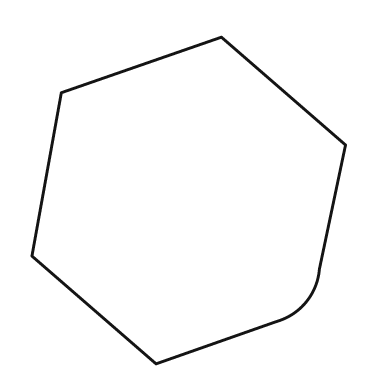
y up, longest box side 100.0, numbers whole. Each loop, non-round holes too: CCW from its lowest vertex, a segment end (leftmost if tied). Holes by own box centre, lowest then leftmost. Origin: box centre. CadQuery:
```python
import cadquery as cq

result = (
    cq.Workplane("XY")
    .moveTo(-10.0, -50.0)
    .lineTo(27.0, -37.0)
    .threePointArc((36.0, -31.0), (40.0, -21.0))
    .lineTo(48.0, 17.0)
    .lineTo(10.0, 50.0)
    .lineTo(-39.0, 33.0)
    .lineTo(-48.0, -17.0)
    .close()
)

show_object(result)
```